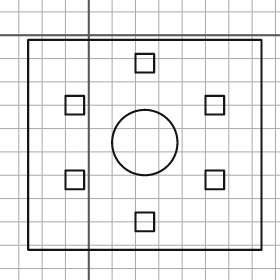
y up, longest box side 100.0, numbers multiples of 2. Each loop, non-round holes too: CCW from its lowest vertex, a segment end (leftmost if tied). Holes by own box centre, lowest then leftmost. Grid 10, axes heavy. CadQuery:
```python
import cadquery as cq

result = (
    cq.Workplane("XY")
    .moveTo(-26.0, -92.0)
    .lineTo(74.0, -92.0)
    .lineTo(74.0, -2.0)
    .lineTo(-26.0, -2.0)
    .close()
    .moveTo(20.0, -84.0)
    .lineTo(28.0, -84.0)
    .lineTo(28.0, -76.0)
    .lineTo(20.0, -76.0)
    .close()
    .moveTo(-10.0, -66.0)
    .lineTo(-2.0, -66.0)
    .lineTo(-2.0, -58.0)
    .lineTo(-10.0, -58.0)
    .close()
    .moveTo(50.0, -66.0)
    .lineTo(58.0, -66.0)
    .lineTo(58.0, -58.0)
    .lineTo(50.0, -58.0)
    .close()
    .moveTo(24.0, -46.0)
    .circle(14.0)
    .moveTo(-10.0, -34.0)
    .lineTo(-2.0, -34.0)
    .lineTo(-2.0, -26.0)
    .lineTo(-10.0, -26.0)
    .close()
    .moveTo(50.0, -34.0)
    .lineTo(58.0, -34.0)
    .lineTo(58.0, -26.0)
    .lineTo(50.0, -26.0)
    .close()
    .moveTo(20.0, -16.0)
    .lineTo(28.0, -16.0)
    .lineTo(28.0, -8.0)
    .lineTo(20.0, -8.0)
    .close()
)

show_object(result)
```